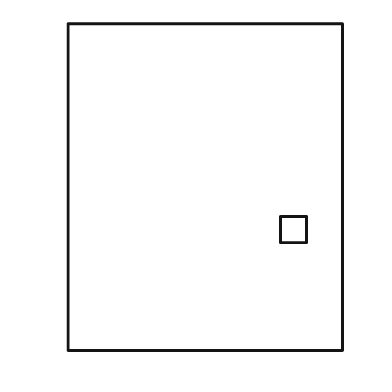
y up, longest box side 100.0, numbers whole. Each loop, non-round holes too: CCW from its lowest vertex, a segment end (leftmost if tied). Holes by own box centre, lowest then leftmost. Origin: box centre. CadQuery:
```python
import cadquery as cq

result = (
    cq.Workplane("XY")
    .moveTo(-42.0, -50.0)
    .lineTo(42.0, -50.0)
    .lineTo(42.0, 50.0)
    .lineTo(-42.0, 50.0)
    .close()
    .moveTo(23.0, -17.0)
    .lineTo(31.0, -17.0)
    .lineTo(31.0, -9.0)
    .lineTo(23.0, -9.0)
    .close()
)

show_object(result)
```